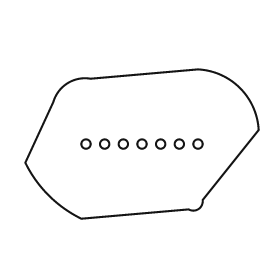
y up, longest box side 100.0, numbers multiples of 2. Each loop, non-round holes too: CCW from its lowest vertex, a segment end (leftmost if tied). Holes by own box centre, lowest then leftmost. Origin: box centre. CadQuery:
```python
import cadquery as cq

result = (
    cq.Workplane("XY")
    .moveTo(-26.0, -32.0)
    .lineTo(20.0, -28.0)
    .threePointArc((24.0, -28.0), (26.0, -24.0))
    .lineTo(50.0, 6.0)
    .threePointArc((42.0, 24.0), (24.0, 32.0))
    .lineTo(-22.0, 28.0)
    .threePointArc((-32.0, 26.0), (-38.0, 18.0))
    .lineTo(-50.0, -8.0)
    .threePointArc((-40.0, -22.0), (-26.0, -32.0))
    .close()
    .moveTo(-24.0, 0.0)
    .circle(2.0)
    .moveTo(-16.0, 0.0)
    .circle(2.0)
    .moveTo(-8.0, 0.0)
    .circle(2.0)
    .moveTo(0.0, 0.0)
    .circle(2.0)
    .moveTo(8.0, 0.0)
    .circle(2.0)
    .moveTo(16.0, 0.0)
    .circle(2.0)
    .moveTo(24.0, 0.0)
    .circle(2.0)
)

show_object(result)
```